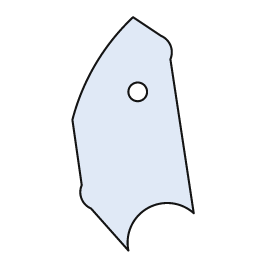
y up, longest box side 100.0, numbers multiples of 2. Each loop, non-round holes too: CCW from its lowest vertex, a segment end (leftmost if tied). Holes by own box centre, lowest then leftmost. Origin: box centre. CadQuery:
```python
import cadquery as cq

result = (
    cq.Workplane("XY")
    .moveTo(-2.0, -50.0)
    .threePointArc((6.0, -32.0), (26.0, -34.0))
    .lineTo(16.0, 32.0)
    .threePointArc((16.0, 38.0), (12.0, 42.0))
    .lineTo(0.0, 50.0)
    .threePointArc((-16.0, 30.0), (-26.0, 6.0))
    .lineTo(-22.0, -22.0)
    .threePointArc((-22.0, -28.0), (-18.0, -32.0))
    .close()
    .moveTo(2.0, 18.0)
    .circle(4.0)
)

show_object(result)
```